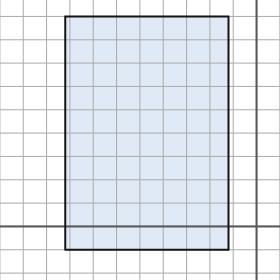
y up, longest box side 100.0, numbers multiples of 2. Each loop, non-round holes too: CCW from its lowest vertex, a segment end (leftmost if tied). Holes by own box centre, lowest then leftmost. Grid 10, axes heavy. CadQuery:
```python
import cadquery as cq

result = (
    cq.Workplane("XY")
    .moveTo(-82.0, -10.0)
    .lineTo(-12.0, -10.0)
    .lineTo(-12.0, 90.0)
    .lineTo(-82.0, 90.0)
    .close()
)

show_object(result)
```